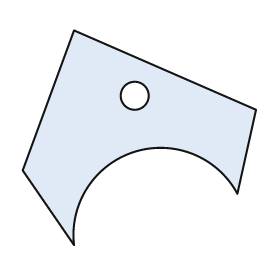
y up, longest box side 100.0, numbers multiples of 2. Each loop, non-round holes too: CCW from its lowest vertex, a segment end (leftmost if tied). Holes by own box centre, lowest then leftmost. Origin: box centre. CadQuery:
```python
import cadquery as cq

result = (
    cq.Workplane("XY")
    .moveTo(-28.0, -46.0)
    .threePointArc((-2.0, -6.0), (42.0, -24.0))
    .lineTo(50.0, 12.0)
    .lineTo(-28.0, 46.0)
    .lineTo(-50.0, -14.0)
    .close()
    .moveTo(-2.0, 18.0)
    .circle(6.0)
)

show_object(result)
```